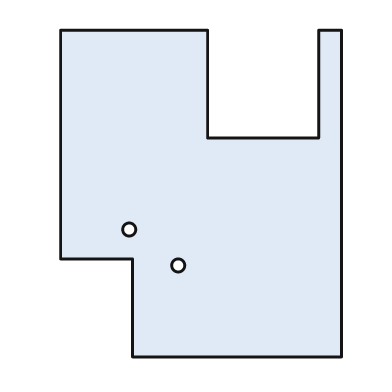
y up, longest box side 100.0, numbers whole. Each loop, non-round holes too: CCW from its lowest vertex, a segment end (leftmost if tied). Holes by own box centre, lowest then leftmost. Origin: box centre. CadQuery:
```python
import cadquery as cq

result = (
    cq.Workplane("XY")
    .moveTo(-21.0, -50.0)
    .lineTo(43.0, -50.0)
    .lineTo(43.0, 50.0)
    .lineTo(36.0, 50.0)
    .lineTo(36.0, 17.0)
    .lineTo(2.0, 17.0)
    .lineTo(2.0, 50.0)
    .lineTo(-43.0, 50.0)
    .lineTo(-43.0, -20.0)
    .lineTo(-21.0, -20.0)
    .close()
    .moveTo(-7.0, -22.0)
    .circle(2.0)
    .moveTo(-22.0, -11.0)
    .circle(2.0)
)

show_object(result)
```